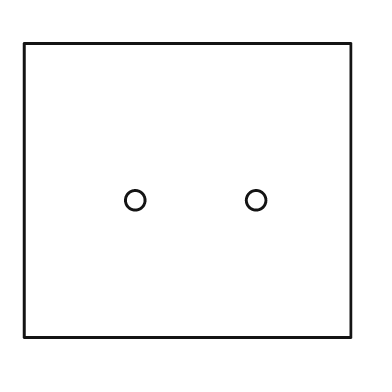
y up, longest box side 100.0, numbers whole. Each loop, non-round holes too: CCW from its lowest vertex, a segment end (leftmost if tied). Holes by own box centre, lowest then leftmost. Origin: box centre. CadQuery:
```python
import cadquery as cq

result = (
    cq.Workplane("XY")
    .moveTo(-50.0, -45.0)
    .lineTo(50.0, -45.0)
    .lineTo(50.0, 45.0)
    .lineTo(-50.0, 45.0)
    .close()
    .moveTo(-16.0, -3.0)
    .circle(3.0)
    .moveTo(21.0, -3.0)
    .circle(3.0)
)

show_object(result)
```